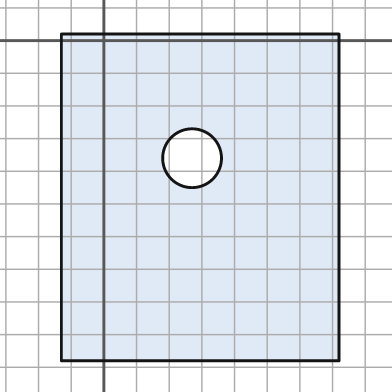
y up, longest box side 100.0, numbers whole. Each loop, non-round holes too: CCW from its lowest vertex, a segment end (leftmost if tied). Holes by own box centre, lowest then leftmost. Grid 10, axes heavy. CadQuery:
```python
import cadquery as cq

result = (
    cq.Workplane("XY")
    .moveTo(-13.0, -98.0)
    .lineTo(72.0, -98.0)
    .lineTo(72.0, 2.0)
    .lineTo(-13.0, 2.0)
    .close()
    .moveTo(27.0, -36.0)
    .circle(9.0)
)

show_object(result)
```